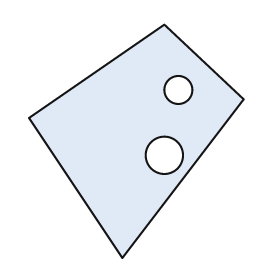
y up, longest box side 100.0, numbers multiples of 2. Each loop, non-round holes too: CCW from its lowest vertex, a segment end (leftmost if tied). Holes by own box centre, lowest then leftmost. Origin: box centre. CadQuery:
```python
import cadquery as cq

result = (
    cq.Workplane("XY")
    .moveTo(-6.0, -50.0)
    .lineTo(46.0, 18.0)
    .lineTo(12.0, 50.0)
    .lineTo(-46.0, 10.0)
    .close()
    .moveTo(12.0, -6.0)
    .circle(8.0)
    .moveTo(18.0, 22.0)
    .circle(6.0)
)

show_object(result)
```